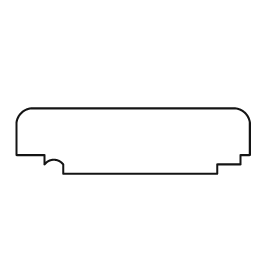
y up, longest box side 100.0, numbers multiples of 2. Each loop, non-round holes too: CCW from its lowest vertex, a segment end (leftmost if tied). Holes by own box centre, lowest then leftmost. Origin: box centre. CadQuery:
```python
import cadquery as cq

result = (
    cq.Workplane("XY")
    .moveTo(-30.0, -14.0)
    .lineTo(36.0, -14.0)
    .lineTo(36.0, -10.0)
    .lineTo(46.0, -10.0)
    .lineTo(46.0, -6.0)
    .lineTo(50.0, -6.0)
    .lineTo(50.0, 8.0)
    .threePointArc((48.0, 12.0), (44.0, 14.0))
    .lineTo(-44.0, 14.0)
    .threePointArc((-48.0, 12.0), (-50.0, 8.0))
    .lineTo(-50.0, -6.0)
    .lineTo(-38.0, -6.0)
    .lineTo(-38.0, -10.0)
    .threePointArc((-34.0, -8.0), (-30.0, -10.0))
    .close()
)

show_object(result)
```